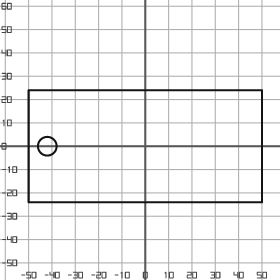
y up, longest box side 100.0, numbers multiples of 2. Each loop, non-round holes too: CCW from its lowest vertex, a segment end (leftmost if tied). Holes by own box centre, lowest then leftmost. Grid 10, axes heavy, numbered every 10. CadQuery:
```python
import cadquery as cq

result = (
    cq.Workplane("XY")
    .moveTo(-50.0, -24.0)
    .lineTo(50.0, -24.0)
    .lineTo(50.0, 24.0)
    .lineTo(-50.0, 24.0)
    .close()
    .moveTo(-42.0, 0.0)
    .circle(4.0)
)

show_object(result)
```